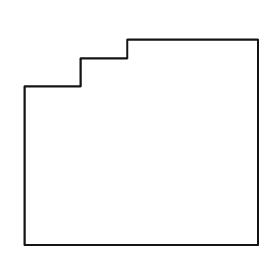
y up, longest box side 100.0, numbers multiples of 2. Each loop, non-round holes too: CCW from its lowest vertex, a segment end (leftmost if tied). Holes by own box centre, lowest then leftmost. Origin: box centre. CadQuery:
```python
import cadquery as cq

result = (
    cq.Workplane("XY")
    .moveTo(-50.0, -44.0)
    .lineTo(50.0, -44.0)
    .lineTo(50.0, 44.0)
    .lineTo(-6.0, 44.0)
    .lineTo(-6.0, 36.0)
    .lineTo(-26.0, 36.0)
    .lineTo(-26.0, 24.0)
    .lineTo(-50.0, 24.0)
    .close()
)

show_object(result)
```